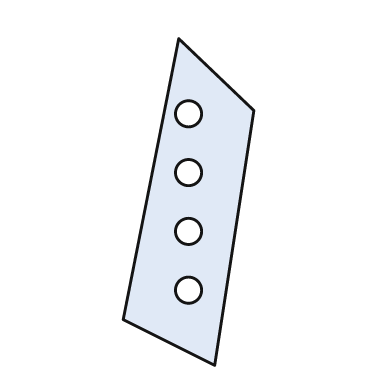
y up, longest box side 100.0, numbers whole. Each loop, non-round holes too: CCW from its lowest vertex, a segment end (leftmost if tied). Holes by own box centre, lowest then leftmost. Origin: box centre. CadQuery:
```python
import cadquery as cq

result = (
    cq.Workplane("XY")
    .moveTo(8.0, -50.0)
    .lineTo(20.0, 28.0)
    .lineTo(-3.0, 50.0)
    .lineTo(-20.0, -36.0)
    .close()
    .moveTo(0.0, -27.0)
    .circle(4.0)
    .moveTo(0.0, -9.0)
    .circle(4.0)
    .moveTo(0.0, 9.0)
    .circle(4.0)
    .moveTo(0.0, 27.0)
    .circle(4.0)
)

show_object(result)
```